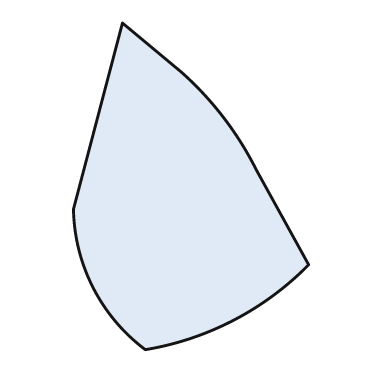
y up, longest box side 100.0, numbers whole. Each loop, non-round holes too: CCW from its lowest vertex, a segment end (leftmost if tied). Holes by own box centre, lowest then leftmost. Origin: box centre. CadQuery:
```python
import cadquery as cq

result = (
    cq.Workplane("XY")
    .moveTo(-14.0, -50.0)
    .threePointArc((13.0, -41.0), (36.0, -24.0))
    .lineTo(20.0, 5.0)
    .threePointArc((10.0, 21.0), (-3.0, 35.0))
    .lineTo(-21.0, 50.0)
    .lineTo(-36.0, -7.0)
    .threePointArc((-30.0, -31.0), (-14.0, -50.0))
    .close()
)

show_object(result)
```